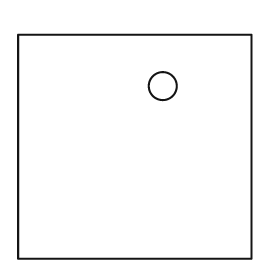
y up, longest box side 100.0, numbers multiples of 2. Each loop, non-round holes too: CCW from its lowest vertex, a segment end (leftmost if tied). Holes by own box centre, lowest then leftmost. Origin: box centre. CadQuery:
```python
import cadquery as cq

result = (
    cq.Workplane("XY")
    .moveTo(-50.0, -48.0)
    .lineTo(50.0, -48.0)
    .lineTo(50.0, 48.0)
    .lineTo(-50.0, 48.0)
    .close()
    .moveTo(12.0, 26.0)
    .circle(6.0)
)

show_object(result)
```